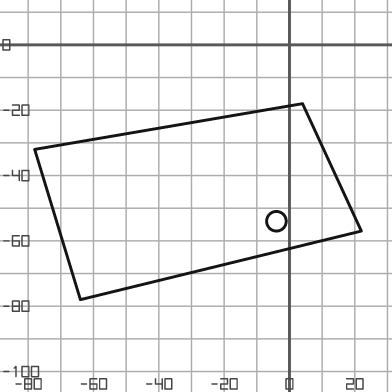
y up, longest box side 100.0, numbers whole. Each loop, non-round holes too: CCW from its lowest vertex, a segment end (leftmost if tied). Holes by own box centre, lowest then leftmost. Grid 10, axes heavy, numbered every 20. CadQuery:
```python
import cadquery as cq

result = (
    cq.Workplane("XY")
    .moveTo(-64.0, -78.0)
    .lineTo(22.0, -57.0)
    .lineTo(4.0, -18.0)
    .lineTo(-78.0, -32.0)
    .close()
    .moveTo(-4.0, -54.0)
    .circle(3.0)
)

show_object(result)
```